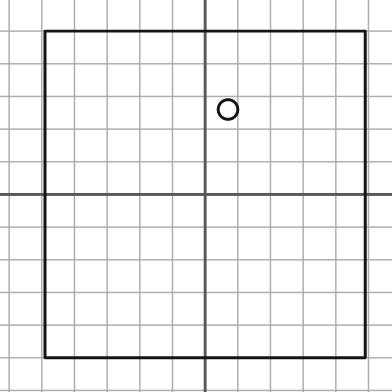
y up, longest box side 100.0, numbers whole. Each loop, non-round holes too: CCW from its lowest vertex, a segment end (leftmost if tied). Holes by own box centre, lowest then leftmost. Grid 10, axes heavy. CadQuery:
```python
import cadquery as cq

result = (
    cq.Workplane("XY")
    .moveTo(-49.0, -50.0)
    .lineTo(49.0, -50.0)
    .lineTo(49.0, 50.0)
    .lineTo(-49.0, 50.0)
    .close()
    .moveTo(7.0, 26.0)
    .circle(3.0)
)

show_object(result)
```